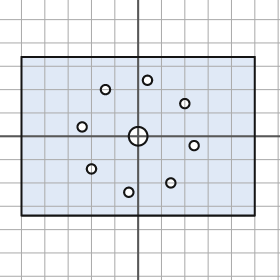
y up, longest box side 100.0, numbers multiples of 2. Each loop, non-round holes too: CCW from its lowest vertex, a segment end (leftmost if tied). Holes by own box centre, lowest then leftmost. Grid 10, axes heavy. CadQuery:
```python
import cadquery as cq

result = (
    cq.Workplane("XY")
    .moveTo(-50.0, -34.0)
    .lineTo(50.0, -34.0)
    .lineTo(50.0, 34.0)
    .lineTo(-50.0, 34.0)
    .close()
    .moveTo(-4.0, -24.0)
    .circle(2.0)
    .moveTo(14.0, -20.0)
    .circle(2.0)
    .moveTo(-20.0, -14.0)
    .circle(2.0)
    .moveTo(24.0, -4.0)
    .circle(2.0)
    .moveTo(0.0, 0.0)
    .circle(4.0)
    .moveTo(-24.0, 4.0)
    .circle(2.0)
    .moveTo(20.0, 14.0)
    .circle(2.0)
    .moveTo(-14.0, 20.0)
    .circle(2.0)
    .moveTo(4.0, 24.0)
    .circle(2.0)
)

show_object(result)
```